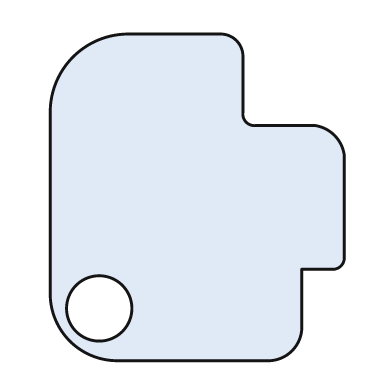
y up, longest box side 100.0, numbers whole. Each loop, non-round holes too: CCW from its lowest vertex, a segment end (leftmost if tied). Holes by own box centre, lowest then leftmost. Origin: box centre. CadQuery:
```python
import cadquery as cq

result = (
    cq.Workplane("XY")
    .moveTo(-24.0, -50.0)
    .lineTo(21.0, -50.0)
    .threePointArc((29.0, -47.0), (32.0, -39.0))
    .lineTo(32.0, -22.0)
    .lineTo(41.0, -22.0)
    .threePointArc((44.0, -21.0), (45.0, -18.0))
    .lineTo(45.0, 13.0)
    .threePointArc((42.0, 19.0), (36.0, 22.0))
    .lineTo(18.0, 22.0)
    .threePointArc((15.0, 23.0), (14.0, 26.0))
    .lineTo(14.0, 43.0)
    .threePointArc((12.0, 48.0), (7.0, 50.0))
    .lineTo(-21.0, 50.0)
    .threePointArc((-38.0, 43.0), (-45.0, 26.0))
    .lineTo(-45.0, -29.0)
    .threePointArc((-39.0, -44.0), (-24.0, -50.0))
    .close()
    .moveTo(-30.0, -34.0)
    .circle(10.0)
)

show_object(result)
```